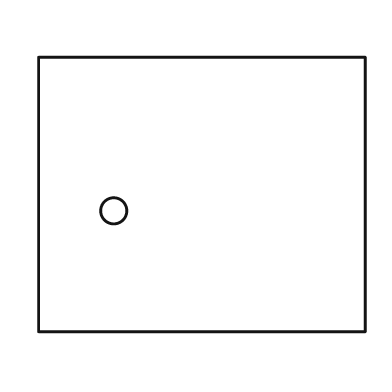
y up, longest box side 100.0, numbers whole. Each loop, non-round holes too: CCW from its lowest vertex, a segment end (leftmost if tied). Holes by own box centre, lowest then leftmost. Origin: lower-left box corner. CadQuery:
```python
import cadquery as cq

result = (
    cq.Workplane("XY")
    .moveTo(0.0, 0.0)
    .lineTo(100.0, 0.0)
    .lineTo(100.0, 84.0)
    .lineTo(0.0, 84.0)
    .close()
    .moveTo(23.0, 37.0)
    .circle(4.0)
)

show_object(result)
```